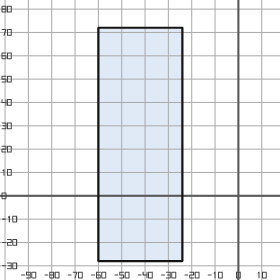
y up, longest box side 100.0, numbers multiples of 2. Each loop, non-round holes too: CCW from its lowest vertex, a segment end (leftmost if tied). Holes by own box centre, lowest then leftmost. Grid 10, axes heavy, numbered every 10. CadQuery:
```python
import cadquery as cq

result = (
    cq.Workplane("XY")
    .moveTo(-60.0, -28.0)
    .lineTo(-24.0, -28.0)
    .lineTo(-24.0, 72.0)
    .lineTo(-60.0, 72.0)
    .close()
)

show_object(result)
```